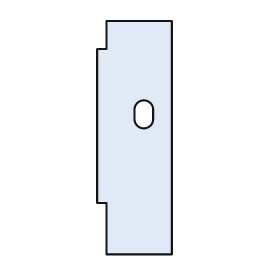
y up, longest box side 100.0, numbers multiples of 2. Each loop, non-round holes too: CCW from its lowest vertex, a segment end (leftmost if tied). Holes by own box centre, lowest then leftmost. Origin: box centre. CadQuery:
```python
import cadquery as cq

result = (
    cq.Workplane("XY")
    .moveTo(-12.0, -50.0)
    .lineTo(16.0, -50.0)
    .lineTo(16.0, 50.0)
    .lineTo(-12.0, 50.0)
    .lineTo(-12.0, 38.0)
    .lineTo(-16.0, 38.0)
    .lineTo(-16.0, -28.0)
    .lineTo(-12.0, -28.0)
    .close()
    .moveTo(0.0, 8.0)
    .threePointArc((4.0, 4.0), (8.0, 8.0))
    .lineTo(8.0, 12.0)
    .threePointArc((4.0, 16.0), (0.0, 12.0))
    .close()
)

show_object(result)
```